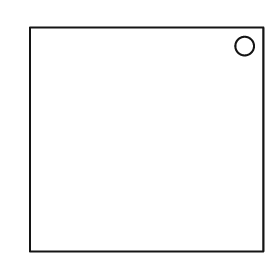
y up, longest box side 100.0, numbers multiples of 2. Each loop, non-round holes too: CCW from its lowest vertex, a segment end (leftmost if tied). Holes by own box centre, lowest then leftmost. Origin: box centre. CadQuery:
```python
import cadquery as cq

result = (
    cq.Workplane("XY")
    .moveTo(-50.0, -48.0)
    .lineTo(50.0, -48.0)
    .lineTo(50.0, 48.0)
    .lineTo(-50.0, 48.0)
    .close()
    .moveTo(42.0, 40.0)
    .circle(4.0)
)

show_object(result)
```